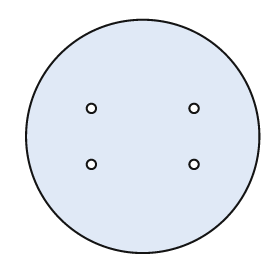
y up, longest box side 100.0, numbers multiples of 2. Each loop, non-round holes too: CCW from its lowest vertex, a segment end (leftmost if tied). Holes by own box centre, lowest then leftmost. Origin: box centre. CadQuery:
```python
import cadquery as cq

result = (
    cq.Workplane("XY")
    .moveTo(0.0, 0.0)
    .circle(50.0)
    .moveTo(-22.0, -12.0)
    .circle(2.0)
    .moveTo(22.0, -12.0)
    .circle(2.0)
    .moveTo(-22.0, 12.0)
    .circle(2.0)
    .moveTo(22.0, 12.0)
    .circle(2.0)
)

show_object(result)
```